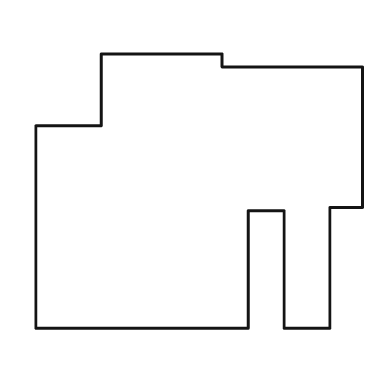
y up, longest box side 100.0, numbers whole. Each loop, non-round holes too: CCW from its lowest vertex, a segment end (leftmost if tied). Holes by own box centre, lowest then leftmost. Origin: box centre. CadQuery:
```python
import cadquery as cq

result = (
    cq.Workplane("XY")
    .moveTo(-50.0, -42.0)
    .lineTo(15.0, -42.0)
    .lineTo(15.0, -6.0)
    .lineTo(26.0, -6.0)
    .lineTo(26.0, -42.0)
    .lineTo(40.0, -42.0)
    .lineTo(40.0, -5.0)
    .lineTo(50.0, -5.0)
    .lineTo(50.0, 38.0)
    .lineTo(7.0, 38.0)
    .lineTo(7.0, 42.0)
    .lineTo(-30.0, 42.0)
    .lineTo(-30.0, 20.0)
    .lineTo(-50.0, 20.0)
    .close()
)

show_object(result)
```